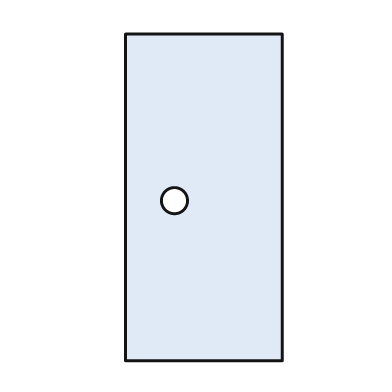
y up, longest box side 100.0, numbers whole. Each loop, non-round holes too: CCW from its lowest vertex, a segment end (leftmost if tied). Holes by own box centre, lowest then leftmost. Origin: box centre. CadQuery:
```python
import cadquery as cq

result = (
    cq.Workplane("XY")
    .moveTo(-24.0, -50.0)
    .lineTo(24.0, -50.0)
    .lineTo(24.0, 50.0)
    .lineTo(-24.0, 50.0)
    .close()
    .moveTo(-9.0, -1.0)
    .circle(4.0)
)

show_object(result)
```